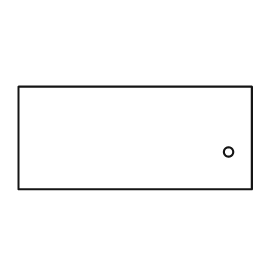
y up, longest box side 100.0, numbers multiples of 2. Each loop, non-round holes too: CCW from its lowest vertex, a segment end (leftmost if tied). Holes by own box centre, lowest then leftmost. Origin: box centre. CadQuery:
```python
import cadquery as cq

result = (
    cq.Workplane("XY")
    .moveTo(-50.0, -22.0)
    .lineTo(50.0, -22.0)
    .lineTo(50.0, 22.0)
    .lineTo(-50.0, 22.0)
    .close()
    .moveTo(40.0, -6.0)
    .circle(2.0)
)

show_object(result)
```